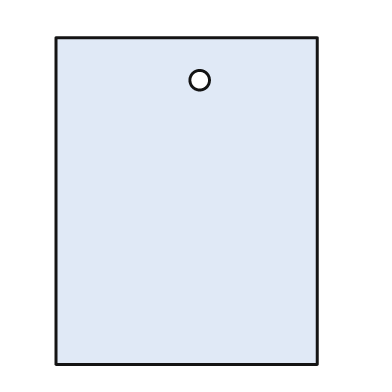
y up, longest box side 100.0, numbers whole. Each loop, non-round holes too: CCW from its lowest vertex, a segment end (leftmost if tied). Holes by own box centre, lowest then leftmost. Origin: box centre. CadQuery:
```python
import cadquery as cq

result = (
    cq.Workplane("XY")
    .moveTo(-40.0, -50.0)
    .lineTo(40.0, -50.0)
    .lineTo(40.0, 50.0)
    .lineTo(-40.0, 50.0)
    .close()
    .moveTo(4.0, 37.0)
    .circle(3.0)
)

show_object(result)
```